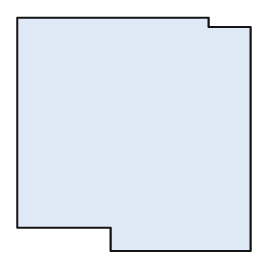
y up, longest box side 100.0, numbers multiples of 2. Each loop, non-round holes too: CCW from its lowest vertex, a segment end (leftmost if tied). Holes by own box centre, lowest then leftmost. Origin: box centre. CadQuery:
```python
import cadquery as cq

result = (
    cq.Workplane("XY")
    .moveTo(-10.0, -50.0)
    .lineTo(50.0, -50.0)
    .lineTo(50.0, 46.0)
    .lineTo(32.0, 46.0)
    .lineTo(32.0, 50.0)
    .lineTo(-50.0, 50.0)
    .lineTo(-50.0, -40.0)
    .lineTo(-10.0, -40.0)
    .close()
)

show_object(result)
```